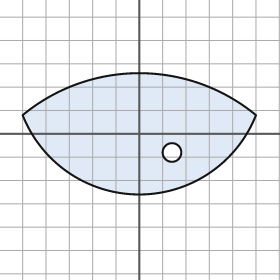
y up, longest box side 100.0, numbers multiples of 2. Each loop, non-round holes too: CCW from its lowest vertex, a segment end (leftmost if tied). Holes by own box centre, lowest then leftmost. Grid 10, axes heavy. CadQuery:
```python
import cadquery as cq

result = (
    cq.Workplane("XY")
    .moveTo(-50.0, 8.0)
    .threePointArc((0.0, -26.0), (50.0, 8.0))
    .threePointArc((0.0, 26.0), (-50.0, 8.0))
    .close()
    .moveTo(14.0, -8.0)
    .circle(4.0)
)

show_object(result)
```